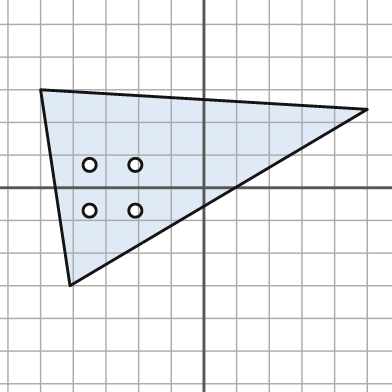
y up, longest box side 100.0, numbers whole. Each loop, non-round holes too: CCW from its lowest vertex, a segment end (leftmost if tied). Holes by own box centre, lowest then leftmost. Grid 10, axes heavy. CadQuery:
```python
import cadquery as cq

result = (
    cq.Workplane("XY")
    .moveTo(-41.0, -30.0)
    .lineTo(50.0, 24.0)
    .lineTo(-50.0, 30.0)
    .close()
    .moveTo(-35.0, -7.0)
    .circle(2.0)
    .moveTo(-21.0, -7.0)
    .circle(2.0)
    .moveTo(-35.0, 7.0)
    .circle(2.0)
    .moveTo(-21.0, 7.0)
    .circle(2.0)
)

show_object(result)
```